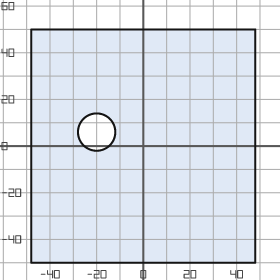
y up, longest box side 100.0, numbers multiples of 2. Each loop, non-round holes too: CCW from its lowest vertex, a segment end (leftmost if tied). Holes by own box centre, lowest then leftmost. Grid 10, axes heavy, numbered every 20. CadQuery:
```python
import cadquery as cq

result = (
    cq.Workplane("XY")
    .moveTo(-48.0, -50.0)
    .lineTo(48.0, -50.0)
    .lineTo(48.0, 50.0)
    .lineTo(-48.0, 50.0)
    .close()
    .moveTo(-20.0, 6.0)
    .circle(8.0)
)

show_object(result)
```